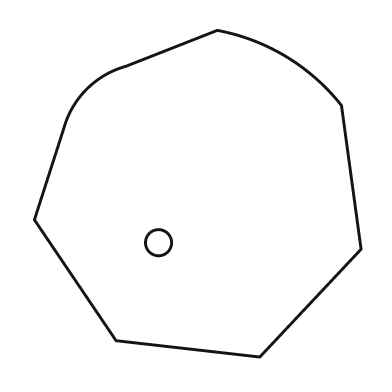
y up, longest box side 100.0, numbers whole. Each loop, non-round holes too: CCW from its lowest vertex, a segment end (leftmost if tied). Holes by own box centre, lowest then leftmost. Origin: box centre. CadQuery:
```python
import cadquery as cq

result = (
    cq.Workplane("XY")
    .moveTo(19.0, -50.0)
    .lineTo(50.0, -17.0)
    .lineTo(44.0, 27.0)
    .threePointArc((27.0, 42.0), (6.0, 50.0))
    .lineTo(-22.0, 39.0)
    .threePointArc((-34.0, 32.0), (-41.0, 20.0))
    .lineTo(-50.0, -8.0)
    .lineTo(-25.0, -45.0)
    .close()
    .moveTo(-12.0, -15.0)
    .circle(4.0)
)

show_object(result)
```